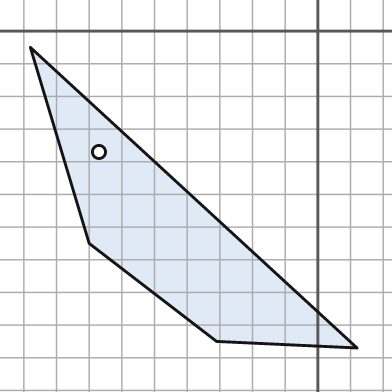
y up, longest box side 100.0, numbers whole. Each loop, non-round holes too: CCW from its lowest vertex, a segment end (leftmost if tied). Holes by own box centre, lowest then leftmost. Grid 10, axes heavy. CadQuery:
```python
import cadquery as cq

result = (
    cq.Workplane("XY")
    .moveTo(12.0, -97.0)
    .lineTo(-88.0, -5.0)
    .lineTo(-70.0, -65.0)
    .lineTo(-31.0, -95.0)
    .close()
    .moveTo(-67.0, -37.0)
    .circle(2.0)
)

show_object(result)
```